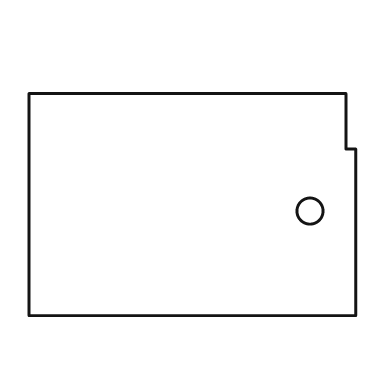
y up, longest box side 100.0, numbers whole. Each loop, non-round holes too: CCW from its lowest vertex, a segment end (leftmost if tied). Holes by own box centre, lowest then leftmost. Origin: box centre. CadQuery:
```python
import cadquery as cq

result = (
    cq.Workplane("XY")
    .moveTo(-50.0, -34.0)
    .lineTo(50.0, -34.0)
    .lineTo(50.0, 17.0)
    .lineTo(47.0, 17.0)
    .lineTo(47.0, 34.0)
    .lineTo(-50.0, 34.0)
    .close()
    .moveTo(36.0, -2.0)
    .circle(4.0)
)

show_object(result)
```